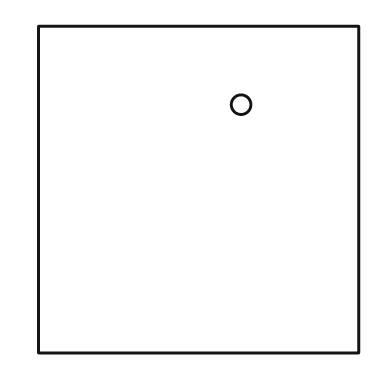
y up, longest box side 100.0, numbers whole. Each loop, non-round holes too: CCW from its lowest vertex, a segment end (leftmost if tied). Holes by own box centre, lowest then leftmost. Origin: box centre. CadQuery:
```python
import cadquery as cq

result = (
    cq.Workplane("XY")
    .moveTo(-49.0, -50.0)
    .lineTo(49.0, -50.0)
    .lineTo(49.0, 50.0)
    .lineTo(-49.0, 50.0)
    .close()
    .moveTo(13.0, 26.0)
    .circle(3.0)
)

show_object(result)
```